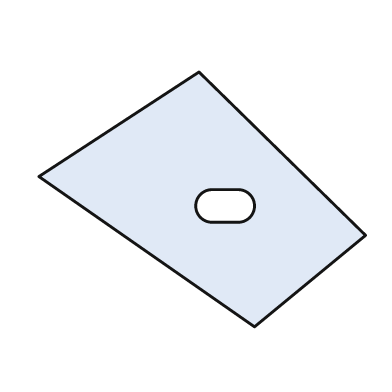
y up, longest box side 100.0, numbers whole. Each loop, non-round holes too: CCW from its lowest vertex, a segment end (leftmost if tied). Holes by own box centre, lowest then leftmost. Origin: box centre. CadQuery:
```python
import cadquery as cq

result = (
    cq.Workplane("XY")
    .moveTo(16.0, -39.0)
    .lineTo(50.0, -11.0)
    .lineTo(-1.0, 39.0)
    .lineTo(-50.0, 7.0)
    .close()
    .moveTo(3.0, -7.0)
    .lineTo(11.0, -7.0)
    .threePointArc((16.0, -2.0), (11.0, 3.0))
    .lineTo(3.0, 3.0)
    .threePointArc((-2.0, -2.0), (3.0, -7.0))
    .close()
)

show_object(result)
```